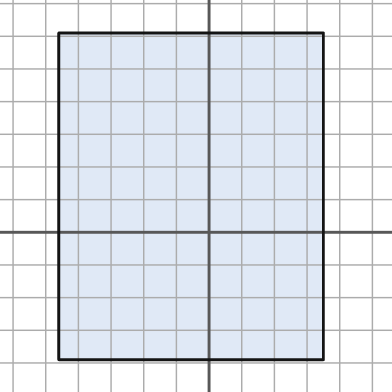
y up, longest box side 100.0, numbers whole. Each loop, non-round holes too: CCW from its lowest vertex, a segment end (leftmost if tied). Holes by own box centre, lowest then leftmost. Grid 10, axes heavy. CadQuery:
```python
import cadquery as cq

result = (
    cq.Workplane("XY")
    .moveTo(-46.0, -39.0)
    .lineTo(35.0, -39.0)
    .lineTo(35.0, 61.0)
    .lineTo(-46.0, 61.0)
    .close()
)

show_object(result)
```